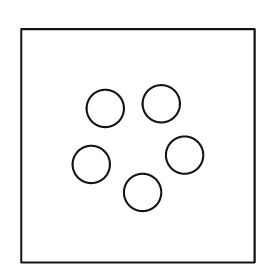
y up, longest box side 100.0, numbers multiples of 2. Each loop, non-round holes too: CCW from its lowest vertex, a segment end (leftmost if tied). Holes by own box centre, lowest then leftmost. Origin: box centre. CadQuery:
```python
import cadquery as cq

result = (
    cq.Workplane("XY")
    .moveTo(-50.0, -50.0)
    .lineTo(50.0, -50.0)
    .lineTo(50.0, 50.0)
    .lineTo(-50.0, 50.0)
    .close()
    .moveTo(2.0, -20.0)
    .circle(8.0)
    .moveTo(-20.0, -8.0)
    .circle(8.0)
    .moveTo(20.0, -4.0)
    .circle(8.0)
    .moveTo(-14.0, 16.0)
    .circle(8.0)
    .moveTo(10.0, 18.0)
    .circle(8.0)
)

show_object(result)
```